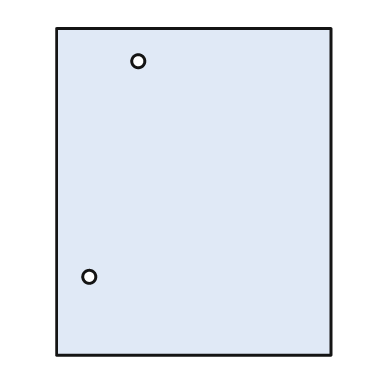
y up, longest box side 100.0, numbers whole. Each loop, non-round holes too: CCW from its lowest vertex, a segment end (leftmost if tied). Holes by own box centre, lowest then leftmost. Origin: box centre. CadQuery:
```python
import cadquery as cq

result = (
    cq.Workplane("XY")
    .moveTo(-42.0, -50.0)
    .lineTo(42.0, -50.0)
    .lineTo(42.0, 50.0)
    .lineTo(-42.0, 50.0)
    .close()
    .moveTo(-32.0, -26.0)
    .circle(2.0)
    .moveTo(-17.0, 40.0)
    .circle(2.0)
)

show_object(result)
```